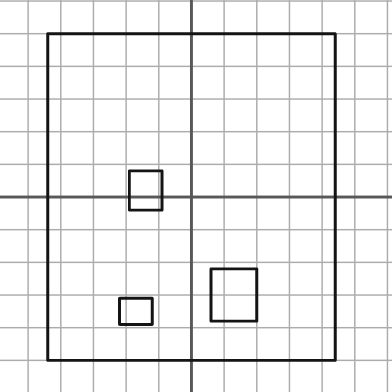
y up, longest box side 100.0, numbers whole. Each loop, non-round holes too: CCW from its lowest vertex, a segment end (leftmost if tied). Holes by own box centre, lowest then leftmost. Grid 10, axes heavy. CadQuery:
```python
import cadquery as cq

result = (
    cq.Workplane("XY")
    .moveTo(-44.0, -50.0)
    .lineTo(44.0, -50.0)
    .lineTo(44.0, 50.0)
    .lineTo(-44.0, 50.0)
    .close()
    .moveTo(-22.0, -39.0)
    .lineTo(-12.0, -39.0)
    .lineTo(-12.0, -31.0)
    .lineTo(-22.0, -31.0)
    .close()
    .moveTo(6.0, -38.0)
    .lineTo(20.0, -38.0)
    .lineTo(20.0, -22.0)
    .lineTo(6.0, -22.0)
    .close()
    .moveTo(-19.0, -4.0)
    .lineTo(-9.0, -4.0)
    .lineTo(-9.0, 8.0)
    .lineTo(-19.0, 8.0)
    .close()
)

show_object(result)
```